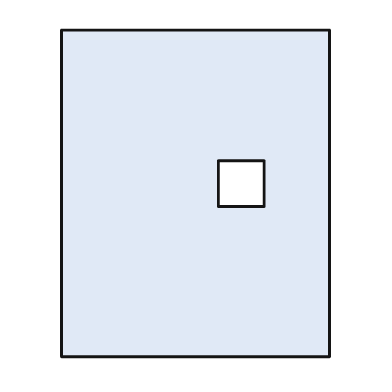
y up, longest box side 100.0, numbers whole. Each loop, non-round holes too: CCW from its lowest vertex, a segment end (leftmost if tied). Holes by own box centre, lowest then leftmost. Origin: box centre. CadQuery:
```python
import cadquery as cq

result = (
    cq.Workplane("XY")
    .moveTo(-41.0, -50.0)
    .lineTo(41.0, -50.0)
    .lineTo(41.0, 50.0)
    .lineTo(-41.0, 50.0)
    .close()
    .moveTo(7.0, -4.0)
    .lineTo(21.0, -4.0)
    .lineTo(21.0, 10.0)
    .lineTo(7.0, 10.0)
    .close()
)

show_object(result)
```